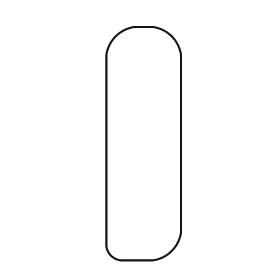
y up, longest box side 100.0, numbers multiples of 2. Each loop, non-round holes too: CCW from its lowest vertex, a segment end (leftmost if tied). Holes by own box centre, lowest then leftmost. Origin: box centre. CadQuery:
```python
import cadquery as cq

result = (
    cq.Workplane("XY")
    .moveTo(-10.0, -50.0)
    .lineTo(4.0, -50.0)
    .threePointArc((12.0, -46.0), (16.0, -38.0))
    .lineTo(16.0, 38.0)
    .threePointArc((12.0, 46.0), (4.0, 50.0))
    .lineTo(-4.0, 50.0)
    .threePointArc((-12.0, 46.0), (-16.0, 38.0))
    .lineTo(-16.0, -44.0)
    .threePointArc((-14.0, -48.0), (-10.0, -50.0))
    .close()
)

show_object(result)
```